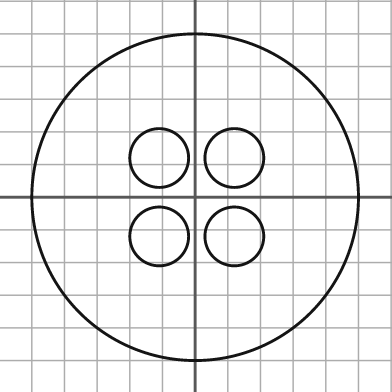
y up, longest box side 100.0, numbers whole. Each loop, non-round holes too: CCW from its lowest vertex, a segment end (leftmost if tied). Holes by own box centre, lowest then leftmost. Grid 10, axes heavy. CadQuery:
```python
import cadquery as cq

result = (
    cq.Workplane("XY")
    .moveTo(0.0, 0.0)
    .circle(50.0)
    .moveTo(-11.0, -12.0)
    .circle(9.0)
    .moveTo(12.0, -12.0)
    .circle(9.0)
    .moveTo(-11.0, 12.0)
    .circle(9.0)
    .moveTo(12.0, 12.0)
    .circle(9.0)
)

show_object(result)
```